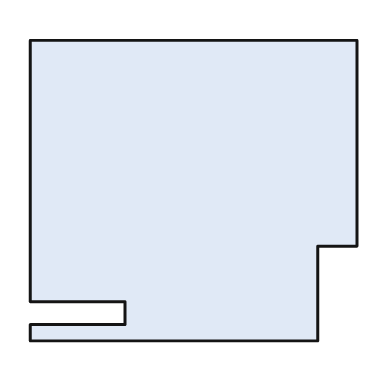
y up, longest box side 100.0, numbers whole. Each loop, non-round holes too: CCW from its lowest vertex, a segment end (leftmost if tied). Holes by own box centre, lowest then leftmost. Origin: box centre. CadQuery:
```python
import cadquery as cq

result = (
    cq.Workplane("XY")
    .moveTo(-50.0, -46.0)
    .lineTo(38.0, -46.0)
    .lineTo(38.0, -17.0)
    .lineTo(50.0, -17.0)
    .lineTo(50.0, 46.0)
    .lineTo(-50.0, 46.0)
    .lineTo(-50.0, -34.0)
    .lineTo(-21.0, -34.0)
    .lineTo(-21.0, -41.0)
    .lineTo(-50.0, -41.0)
    .close()
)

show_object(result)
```